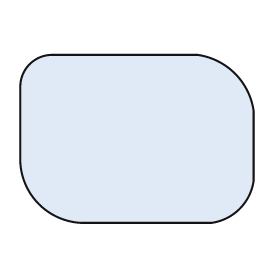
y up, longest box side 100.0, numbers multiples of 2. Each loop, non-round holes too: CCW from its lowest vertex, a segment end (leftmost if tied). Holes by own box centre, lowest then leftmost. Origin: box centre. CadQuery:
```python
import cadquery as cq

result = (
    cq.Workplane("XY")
    .moveTo(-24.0, -36.0)
    .lineTo(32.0, -36.0)
    .threePointArc((44.0, -30.0), (50.0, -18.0))
    .lineTo(50.0, 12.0)
    .threePointArc((42.0, 28.0), (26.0, 36.0))
    .lineTo(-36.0, 36.0)
    .threePointArc((-46.0, 32.0), (-50.0, 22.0))
    .lineTo(-50.0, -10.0)
    .threePointArc((-42.0, -28.0), (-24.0, -36.0))
    .close()
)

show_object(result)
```